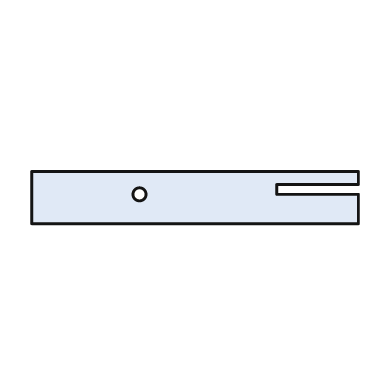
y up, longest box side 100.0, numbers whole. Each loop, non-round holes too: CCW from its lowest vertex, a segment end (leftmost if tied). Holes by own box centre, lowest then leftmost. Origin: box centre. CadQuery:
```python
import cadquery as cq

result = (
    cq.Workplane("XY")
    .moveTo(-50.0, -8.0)
    .lineTo(50.0, -8.0)
    .lineTo(50.0, 1.0)
    .lineTo(25.0, 1.0)
    .lineTo(25.0, 4.0)
    .lineTo(50.0, 4.0)
    .lineTo(50.0, 8.0)
    .lineTo(-50.0, 8.0)
    .close()
    .moveTo(-17.0, 1.0)
    .circle(2.0)
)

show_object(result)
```